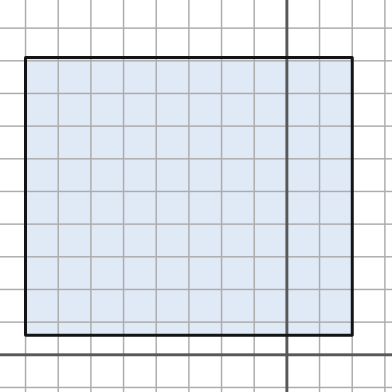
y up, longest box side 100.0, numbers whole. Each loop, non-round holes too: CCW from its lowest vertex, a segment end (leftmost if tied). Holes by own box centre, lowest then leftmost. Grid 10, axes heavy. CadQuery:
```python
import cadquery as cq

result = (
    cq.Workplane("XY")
    .moveTo(-80.0, 6.0)
    .lineTo(20.0, 6.0)
    .lineTo(20.0, 91.0)
    .lineTo(-80.0, 91.0)
    .close()
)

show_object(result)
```